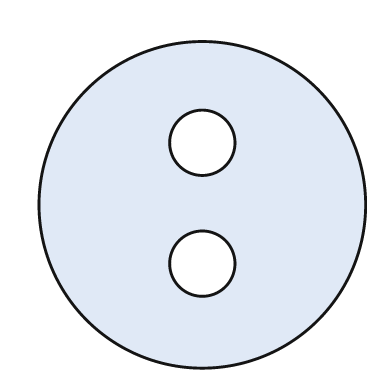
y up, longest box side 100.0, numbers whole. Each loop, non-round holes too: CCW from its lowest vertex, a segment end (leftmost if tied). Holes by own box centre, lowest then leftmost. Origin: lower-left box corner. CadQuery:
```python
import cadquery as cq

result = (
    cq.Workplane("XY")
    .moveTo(50.0, 50.0)
    .circle(50.0)
    .moveTo(50.0, 32.0)
    .circle(10.0)
    .moveTo(50.0, 69.0)
    .circle(10.0)
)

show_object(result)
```